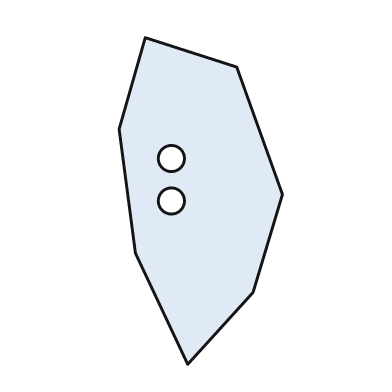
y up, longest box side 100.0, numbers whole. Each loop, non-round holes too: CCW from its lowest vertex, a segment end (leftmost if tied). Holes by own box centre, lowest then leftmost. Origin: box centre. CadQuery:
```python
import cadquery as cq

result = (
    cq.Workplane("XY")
    .moveTo(-4.0, -50.0)
    .lineTo(16.0, -28.0)
    .lineTo(25.0, 2.0)
    .lineTo(11.0, 41.0)
    .lineTo(-17.0, 50.0)
    .lineTo(-25.0, 22.0)
    .lineTo(-20.0, -16.0)
    .close()
    .moveTo(-9.0, 0.0)
    .circle(4.0)
    .moveTo(-9.0, 13.0)
    .circle(4.0)
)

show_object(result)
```